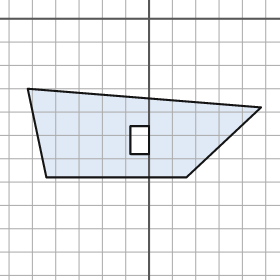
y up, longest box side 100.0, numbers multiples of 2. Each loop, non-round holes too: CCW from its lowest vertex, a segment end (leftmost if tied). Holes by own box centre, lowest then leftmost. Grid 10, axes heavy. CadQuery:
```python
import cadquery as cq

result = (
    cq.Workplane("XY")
    .moveTo(-44.0, -68.0)
    .lineTo(16.0, -68.0)
    .lineTo(48.0, -38.0)
    .lineTo(-52.0, -30.0)
    .close()
    .moveTo(-8.0, -58.0)
    .lineTo(0.0, -58.0)
    .lineTo(0.0, -46.0)
    .lineTo(-8.0, -46.0)
    .close()
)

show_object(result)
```